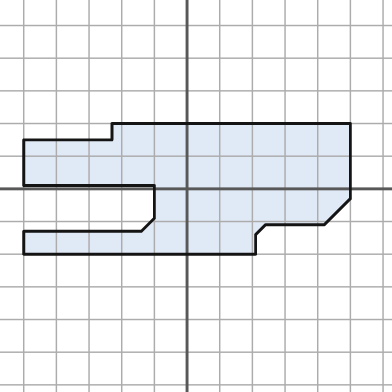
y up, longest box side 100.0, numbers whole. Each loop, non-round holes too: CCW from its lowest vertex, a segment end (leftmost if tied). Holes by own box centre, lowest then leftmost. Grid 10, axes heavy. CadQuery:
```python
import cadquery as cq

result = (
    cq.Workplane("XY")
    .moveTo(-50.0, -20.0)
    .lineTo(21.0, -20.0)
    .lineTo(21.0, -14.0)
    .lineTo(24.0, -11.0)
    .lineTo(42.0, -11.0)
    .lineTo(50.0, -3.0)
    .lineTo(50.0, 20.0)
    .lineTo(-23.0, 20.0)
    .lineTo(-23.0, 15.0)
    .lineTo(-50.0, 15.0)
    .lineTo(-50.0, 1.0)
    .lineTo(-10.0, 1.0)
    .lineTo(-10.0, -9.0)
    .lineTo(-14.0, -13.0)
    .lineTo(-50.0, -13.0)
    .close()
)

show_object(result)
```